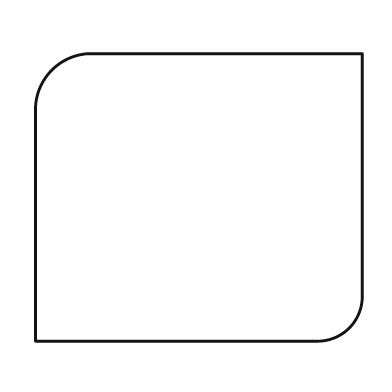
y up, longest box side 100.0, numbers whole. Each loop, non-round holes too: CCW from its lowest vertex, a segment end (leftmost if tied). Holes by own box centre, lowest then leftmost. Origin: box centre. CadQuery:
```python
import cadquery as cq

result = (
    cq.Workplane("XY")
    .moveTo(-50.0, -44.0)
    .lineTo(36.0, -44.0)
    .threePointArc((46.0, -40.0), (50.0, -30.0))
    .lineTo(50.0, 44.0)
    .lineTo(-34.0, 44.0)
    .threePointArc((-45.0, 39.0), (-50.0, 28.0))
    .close()
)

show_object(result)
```